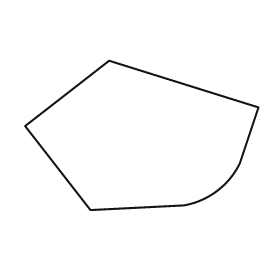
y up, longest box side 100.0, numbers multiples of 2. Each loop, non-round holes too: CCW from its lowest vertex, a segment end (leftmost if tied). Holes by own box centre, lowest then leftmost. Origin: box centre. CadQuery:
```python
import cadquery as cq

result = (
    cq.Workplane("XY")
    .moveTo(-22.0, -32.0)
    .lineTo(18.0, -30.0)
    .threePointArc((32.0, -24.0), (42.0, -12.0))
    .lineTo(50.0, 12.0)
    .lineTo(-14.0, 32.0)
    .lineTo(-50.0, 4.0)
    .close()
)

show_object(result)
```